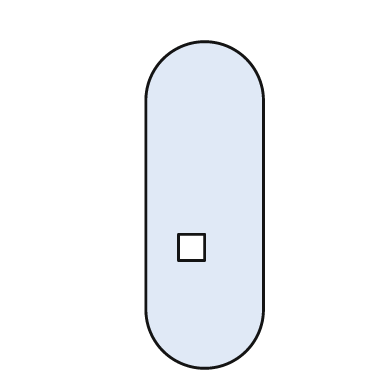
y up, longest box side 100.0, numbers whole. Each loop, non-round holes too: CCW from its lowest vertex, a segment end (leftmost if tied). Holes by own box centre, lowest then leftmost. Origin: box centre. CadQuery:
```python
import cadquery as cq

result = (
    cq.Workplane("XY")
    .moveTo(-18.0, -32.0)
    .threePointArc((0.0, -50.0), (18.0, -32.0))
    .lineTo(18.0, 32.0)
    .threePointArc((0.0, 50.0), (-18.0, 32.0))
    .close()
    .moveTo(-8.0, -17.0)
    .lineTo(0.0, -17.0)
    .lineTo(0.0, -9.0)
    .lineTo(-8.0, -9.0)
    .close()
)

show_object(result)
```